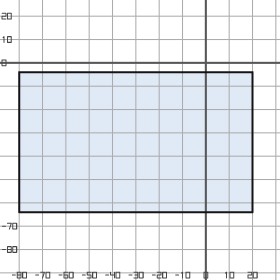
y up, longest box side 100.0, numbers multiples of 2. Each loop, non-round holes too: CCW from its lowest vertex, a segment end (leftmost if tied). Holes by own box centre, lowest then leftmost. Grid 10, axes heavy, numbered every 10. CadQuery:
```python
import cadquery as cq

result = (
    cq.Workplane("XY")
    .moveTo(-80.0, -64.0)
    .lineTo(20.0, -64.0)
    .lineTo(20.0, -4.0)
    .lineTo(-80.0, -4.0)
    .close()
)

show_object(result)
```